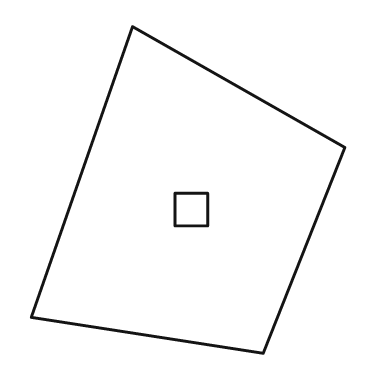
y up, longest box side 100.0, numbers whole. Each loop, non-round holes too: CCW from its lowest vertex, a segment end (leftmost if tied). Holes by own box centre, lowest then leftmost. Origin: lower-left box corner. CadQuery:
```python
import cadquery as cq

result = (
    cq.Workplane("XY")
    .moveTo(71.0, 0.0)
    .lineTo(96.0, 63.0)
    .lineTo(31.0, 100.0)
    .lineTo(0.0, 11.0)
    .close()
    .moveTo(44.0, 39.0)
    .lineTo(54.0, 39.0)
    .lineTo(54.0, 49.0)
    .lineTo(44.0, 49.0)
    .close()
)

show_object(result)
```